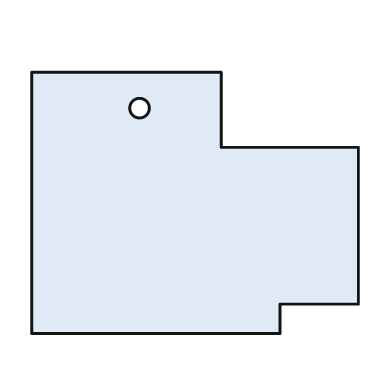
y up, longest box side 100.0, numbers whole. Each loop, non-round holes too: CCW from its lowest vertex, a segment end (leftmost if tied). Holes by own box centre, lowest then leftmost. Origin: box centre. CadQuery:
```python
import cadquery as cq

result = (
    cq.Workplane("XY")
    .moveTo(-50.0, -40.0)
    .lineTo(26.0, -40.0)
    .lineTo(26.0, -31.0)
    .lineTo(50.0, -31.0)
    .lineTo(50.0, 17.0)
    .lineTo(8.0, 17.0)
    .lineTo(8.0, 40.0)
    .lineTo(-50.0, 40.0)
    .close()
    .moveTo(-17.0, 29.0)
    .circle(3.0)
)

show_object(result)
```